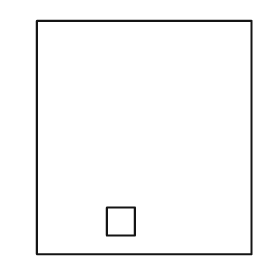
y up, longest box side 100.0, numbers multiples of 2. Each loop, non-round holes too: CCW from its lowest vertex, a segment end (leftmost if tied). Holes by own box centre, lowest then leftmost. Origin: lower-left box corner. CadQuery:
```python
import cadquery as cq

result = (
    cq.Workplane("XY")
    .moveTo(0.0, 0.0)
    .lineTo(92.0, 0.0)
    .lineTo(92.0, 100.0)
    .lineTo(0.0, 100.0)
    .close()
    .moveTo(30.0, 8.0)
    .lineTo(42.0, 8.0)
    .lineTo(42.0, 20.0)
    .lineTo(30.0, 20.0)
    .close()
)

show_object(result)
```